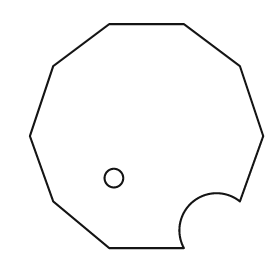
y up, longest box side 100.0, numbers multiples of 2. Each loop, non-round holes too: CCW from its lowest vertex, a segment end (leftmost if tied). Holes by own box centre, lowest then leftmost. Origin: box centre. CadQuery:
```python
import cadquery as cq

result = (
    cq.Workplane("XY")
    .moveTo(-16.0, -48.0)
    .lineTo(16.0, -48.0)
    .threePointArc((20.0, -28.0), (40.0, -28.0))
    .lineTo(50.0, 0.0)
    .lineTo(40.0, 30.0)
    .lineTo(16.0, 48.0)
    .lineTo(-16.0, 48.0)
    .lineTo(-40.0, 30.0)
    .lineTo(-50.0, 0.0)
    .lineTo(-40.0, -28.0)
    .close()
    .moveTo(-14.0, -18.0)
    .circle(4.0)
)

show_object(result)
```